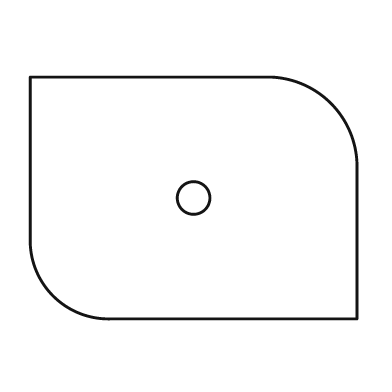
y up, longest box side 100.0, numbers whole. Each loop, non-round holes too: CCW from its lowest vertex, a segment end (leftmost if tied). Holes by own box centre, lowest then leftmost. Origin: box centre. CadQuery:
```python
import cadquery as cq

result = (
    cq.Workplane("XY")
    .moveTo(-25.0, -37.0)
    .lineTo(50.0, -37.0)
    .lineTo(50.0, 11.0)
    .threePointArc((42.0, 29.0), (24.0, 37.0))
    .lineTo(-50.0, 37.0)
    .lineTo(-50.0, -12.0)
    .threePointArc((-43.0, -30.0), (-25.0, -37.0))
    .close()
    .moveTo(0.0, 0.0)
    .circle(5.0)
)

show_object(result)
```